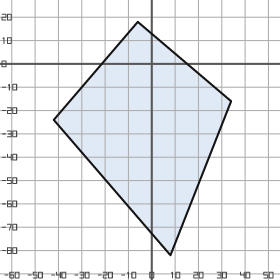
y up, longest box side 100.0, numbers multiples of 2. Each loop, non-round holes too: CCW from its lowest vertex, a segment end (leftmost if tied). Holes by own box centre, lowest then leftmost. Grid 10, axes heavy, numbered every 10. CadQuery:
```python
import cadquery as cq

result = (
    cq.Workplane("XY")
    .moveTo(8.0, -82.0)
    .lineTo(34.0, -16.0)
    .lineTo(-6.0, 18.0)
    .lineTo(-42.0, -24.0)
    .close()
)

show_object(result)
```